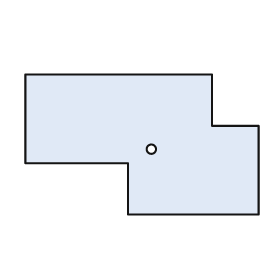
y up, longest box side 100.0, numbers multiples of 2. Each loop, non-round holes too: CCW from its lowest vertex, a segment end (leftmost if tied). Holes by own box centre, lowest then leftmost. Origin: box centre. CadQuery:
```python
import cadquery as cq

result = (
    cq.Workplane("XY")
    .moveTo(-6.0, -30.0)
    .lineTo(50.0, -30.0)
    .lineTo(50.0, 8.0)
    .lineTo(30.0, 8.0)
    .lineTo(30.0, 30.0)
    .lineTo(-50.0, 30.0)
    .lineTo(-50.0, -8.0)
    .lineTo(-6.0, -8.0)
    .close()
    .moveTo(4.0, -2.0)
    .circle(2.0)
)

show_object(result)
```